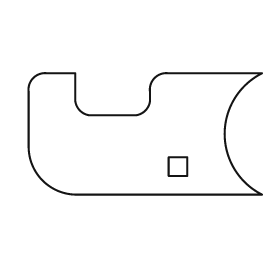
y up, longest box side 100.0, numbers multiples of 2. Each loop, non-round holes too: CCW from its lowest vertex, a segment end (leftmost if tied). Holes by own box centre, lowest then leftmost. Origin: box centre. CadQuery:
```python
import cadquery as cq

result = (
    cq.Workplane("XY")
    .moveTo(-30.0, -26.0)
    .lineTo(50.0, -26.0)
    .threePointArc((34.0, 0.0), (50.0, 26.0))
    .lineTo(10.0, 26.0)
    .threePointArc((4.0, 24.0), (2.0, 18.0))
    .lineTo(2.0, 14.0)
    .threePointArc((0.0, 10.0), (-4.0, 8.0))
    .lineTo(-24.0, 8.0)
    .threePointArc((-28.0, 10.0), (-30.0, 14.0))
    .lineTo(-30.0, 26.0)
    .lineTo(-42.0, 26.0)
    .threePointArc((-48.0, 24.0), (-50.0, 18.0))
    .lineTo(-50.0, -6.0)
    .threePointArc((-44.0, -20.0), (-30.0, -26.0))
    .close()
    .moveTo(10.0, -18.0)
    .lineTo(18.0, -18.0)
    .lineTo(18.0, -10.0)
    .lineTo(10.0, -10.0)
    .close()
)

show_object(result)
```